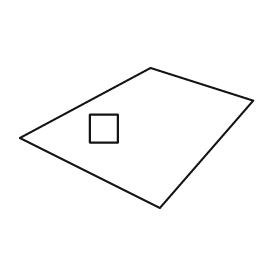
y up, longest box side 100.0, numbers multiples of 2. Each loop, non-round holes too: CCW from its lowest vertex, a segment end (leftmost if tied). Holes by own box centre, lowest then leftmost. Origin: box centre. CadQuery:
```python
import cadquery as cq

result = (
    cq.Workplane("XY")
    .moveTo(10.0, -30.0)
    .lineTo(50.0, 16.0)
    .lineTo(6.0, 30.0)
    .lineTo(-50.0, 0.0)
    .close()
    .moveTo(-20.0, -2.0)
    .lineTo(-8.0, -2.0)
    .lineTo(-8.0, 10.0)
    .lineTo(-20.0, 10.0)
    .close()
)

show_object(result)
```